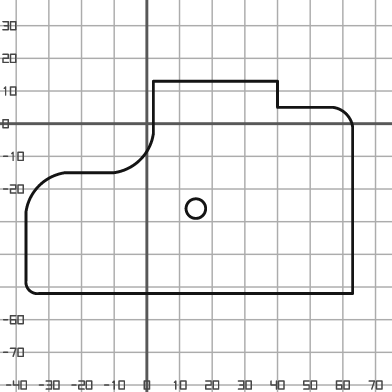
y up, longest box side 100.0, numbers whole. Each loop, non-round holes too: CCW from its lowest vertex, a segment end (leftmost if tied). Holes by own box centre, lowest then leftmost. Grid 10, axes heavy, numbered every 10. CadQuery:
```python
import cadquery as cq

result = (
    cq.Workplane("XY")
    .moveTo(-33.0, -52.0)
    .lineTo(63.0, -52.0)
    .lineTo(63.0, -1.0)
    .threePointArc((61.0, 3.0), (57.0, 5.0))
    .lineTo(40.0, 5.0)
    .lineTo(40.0, 13.0)
    .lineTo(2.0, 13.0)
    .lineTo(2.0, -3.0)
    .threePointArc((-2.0, -11.0), (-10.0, -15.0))
    .lineTo(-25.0, -15.0)
    .threePointArc((-33.0, -19.0), (-37.0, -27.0))
    .lineTo(-37.0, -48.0)
    .threePointArc((-36.0, -51.0), (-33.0, -52.0))
    .close()
    .moveTo(15.0, -26.0)
    .circle(3.0)
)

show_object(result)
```